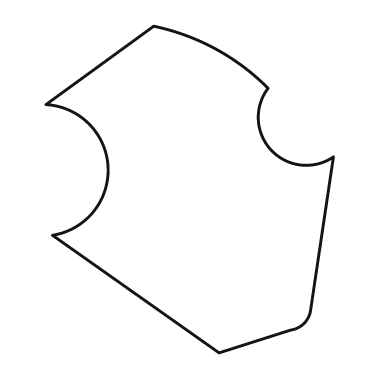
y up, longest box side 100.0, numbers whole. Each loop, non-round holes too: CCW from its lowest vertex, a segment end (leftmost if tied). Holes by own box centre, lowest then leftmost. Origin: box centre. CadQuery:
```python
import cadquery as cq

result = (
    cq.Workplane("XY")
    .moveTo(9.0, -50.0)
    .lineTo(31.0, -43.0)
    .threePointArc((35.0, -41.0), (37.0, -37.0))
    .lineTo(44.0, 10.0)
    .threePointArc((25.0, 12.0), (24.0, 31.0))
    .threePointArc((8.0, 43.0), (-11.0, 50.0))
    .lineTo(-44.0, 26.0)
    .threePointArc((-25.0, 7.0), (-42.0, -14.0))
    .close()
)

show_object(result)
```